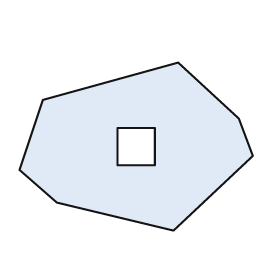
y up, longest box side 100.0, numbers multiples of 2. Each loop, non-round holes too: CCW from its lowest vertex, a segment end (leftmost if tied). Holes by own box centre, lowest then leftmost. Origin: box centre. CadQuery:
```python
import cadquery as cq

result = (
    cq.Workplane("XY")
    .moveTo(16.0, -36.0)
    .lineTo(50.0, -4.0)
    .lineTo(44.0, 12.0)
    .lineTo(18.0, 36.0)
    .lineTo(-40.0, 20.0)
    .lineTo(-50.0, -10.0)
    .lineTo(-34.0, -24.0)
    .close()
    .moveTo(-8.0, -8.0)
    .lineTo(8.0, -8.0)
    .lineTo(8.0, 8.0)
    .lineTo(-8.0, 8.0)
    .close()
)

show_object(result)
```